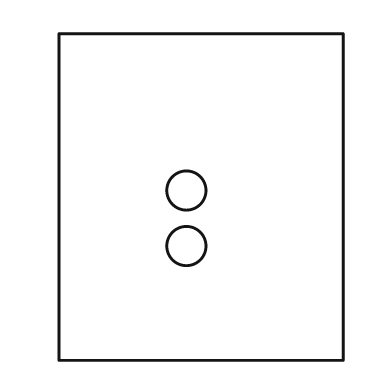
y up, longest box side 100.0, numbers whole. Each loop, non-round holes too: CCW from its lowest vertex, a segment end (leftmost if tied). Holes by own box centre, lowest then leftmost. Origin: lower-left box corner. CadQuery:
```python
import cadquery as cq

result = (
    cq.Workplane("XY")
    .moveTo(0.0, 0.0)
    .lineTo(87.0, 0.0)
    .lineTo(87.0, 100.0)
    .lineTo(0.0, 100.0)
    .close()
    .moveTo(39.0, 35.0)
    .circle(6.0)
    .moveTo(39.0, 52.0)
    .circle(6.0)
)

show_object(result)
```